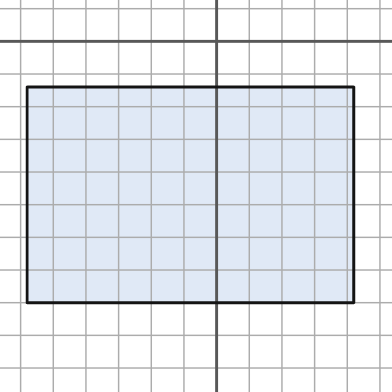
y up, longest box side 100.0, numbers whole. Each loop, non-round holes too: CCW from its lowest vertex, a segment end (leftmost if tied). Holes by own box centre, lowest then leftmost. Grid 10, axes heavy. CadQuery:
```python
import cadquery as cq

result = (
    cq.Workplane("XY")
    .moveTo(-58.0, -80.0)
    .lineTo(42.0, -80.0)
    .lineTo(42.0, -14.0)
    .lineTo(-58.0, -14.0)
    .close()
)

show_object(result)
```